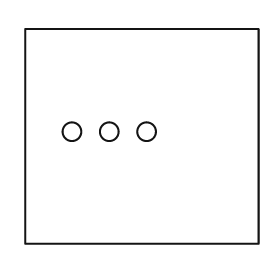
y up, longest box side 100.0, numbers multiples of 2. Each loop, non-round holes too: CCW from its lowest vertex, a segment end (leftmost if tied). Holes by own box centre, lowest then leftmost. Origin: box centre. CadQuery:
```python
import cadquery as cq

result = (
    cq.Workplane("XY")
    .moveTo(-50.0, -46.0)
    .lineTo(50.0, -46.0)
    .lineTo(50.0, 46.0)
    .lineTo(-50.0, 46.0)
    .close()
    .moveTo(-30.0, 2.0)
    .circle(4.0)
    .moveTo(-14.0, 2.0)
    .circle(4.0)
    .moveTo(2.0, 2.0)
    .circle(4.0)
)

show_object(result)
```